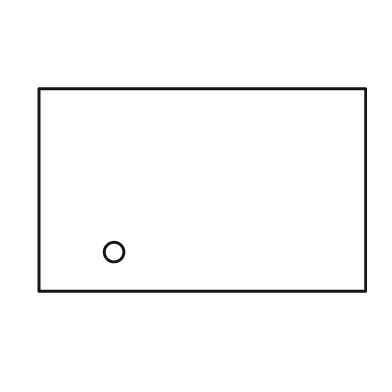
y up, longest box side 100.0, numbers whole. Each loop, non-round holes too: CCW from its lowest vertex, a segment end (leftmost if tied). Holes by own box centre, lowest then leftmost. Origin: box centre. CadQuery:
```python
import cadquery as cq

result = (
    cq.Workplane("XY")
    .moveTo(-50.0, -31.0)
    .lineTo(50.0, -31.0)
    .lineTo(50.0, 31.0)
    .lineTo(-50.0, 31.0)
    .close()
    .moveTo(-27.0, -19.0)
    .circle(3.0)
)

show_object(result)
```